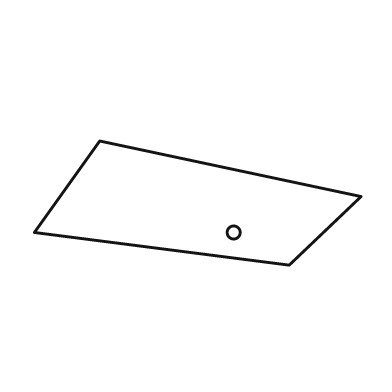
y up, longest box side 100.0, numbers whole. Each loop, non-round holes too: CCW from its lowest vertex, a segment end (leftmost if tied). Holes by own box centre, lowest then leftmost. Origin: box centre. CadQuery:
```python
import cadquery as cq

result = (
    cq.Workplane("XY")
    .moveTo(28.0, -19.0)
    .lineTo(50.0, 2.0)
    .lineTo(-30.0, 19.0)
    .lineTo(-50.0, -9.0)
    .close()
    .moveTo(11.0, -9.0)
    .circle(2.0)
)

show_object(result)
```